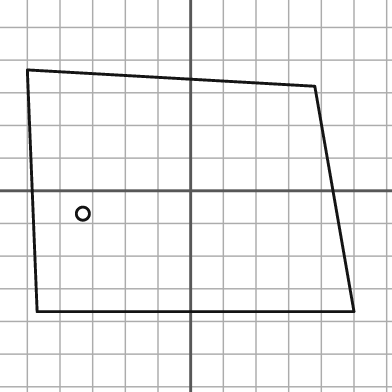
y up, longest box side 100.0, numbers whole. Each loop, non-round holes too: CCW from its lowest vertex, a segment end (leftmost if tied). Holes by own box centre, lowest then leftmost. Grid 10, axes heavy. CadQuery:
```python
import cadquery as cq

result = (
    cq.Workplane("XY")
    .moveTo(-47.0, -37.0)
    .lineTo(50.0, -37.0)
    .lineTo(38.0, 32.0)
    .lineTo(-50.0, 37.0)
    .close()
    .moveTo(-33.0, -7.0)
    .circle(2.0)
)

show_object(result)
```